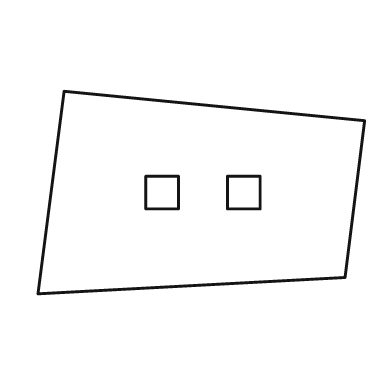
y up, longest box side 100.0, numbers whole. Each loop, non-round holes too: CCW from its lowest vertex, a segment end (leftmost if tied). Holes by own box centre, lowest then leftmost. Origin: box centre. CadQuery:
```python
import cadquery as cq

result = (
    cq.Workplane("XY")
    .moveTo(-50.0, -31.0)
    .lineTo(44.0, -26.0)
    .lineTo(50.0, 22.0)
    .lineTo(-42.0, 31.0)
    .close()
    .moveTo(-17.0, -5.0)
    .lineTo(-7.0, -5.0)
    .lineTo(-7.0, 5.0)
    .lineTo(-17.0, 5.0)
    .close()
    .moveTo(8.0, -5.0)
    .lineTo(18.0, -5.0)
    .lineTo(18.0, 5.0)
    .lineTo(8.0, 5.0)
    .close()
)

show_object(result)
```